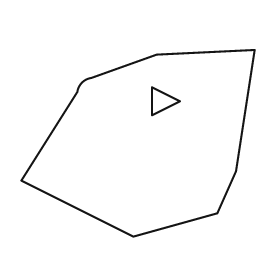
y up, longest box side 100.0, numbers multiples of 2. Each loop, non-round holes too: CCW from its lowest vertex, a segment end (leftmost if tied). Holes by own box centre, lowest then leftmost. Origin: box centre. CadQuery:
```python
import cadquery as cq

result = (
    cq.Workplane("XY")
    .moveTo(-2.0, -40.0)
    .lineTo(34.0, -30.0)
    .lineTo(42.0, -12.0)
    .lineTo(50.0, 40.0)
    .lineTo(8.0, 38.0)
    .lineTo(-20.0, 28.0)
    .threePointArc((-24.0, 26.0), (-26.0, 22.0))
    .lineTo(-50.0, -16.0)
    .close()
    .moveTo(6.0, 12.0)
    .lineTo(18.0, 18.0)
    .lineTo(6.0, 24.0)
    .close()
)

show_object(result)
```